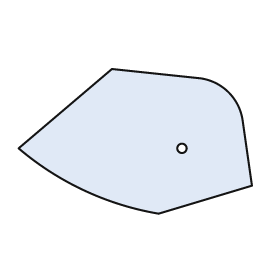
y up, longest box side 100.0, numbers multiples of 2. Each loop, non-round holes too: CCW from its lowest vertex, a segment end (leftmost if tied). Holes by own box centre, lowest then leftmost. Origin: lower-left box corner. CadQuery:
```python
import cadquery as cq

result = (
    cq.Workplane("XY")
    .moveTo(60.0, 0.0)
    .lineTo(100.0, 12.0)
    .lineTo(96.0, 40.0)
    .threePointArc((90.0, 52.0), (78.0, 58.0))
    .lineTo(40.0, 62.0)
    .lineTo(0.0, 28.0)
    .threePointArc((28.0, 10.0), (60.0, 0.0))
    .close()
    .moveTo(70.0, 28.0)
    .circle(2.0)
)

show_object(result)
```